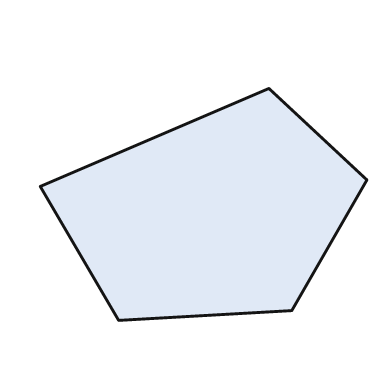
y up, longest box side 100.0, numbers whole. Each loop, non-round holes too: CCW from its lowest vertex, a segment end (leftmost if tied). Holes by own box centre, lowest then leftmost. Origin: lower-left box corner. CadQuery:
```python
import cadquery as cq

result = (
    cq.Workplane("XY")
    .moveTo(24.0, 0.0)
    .lineTo(77.0, 3.0)
    .lineTo(100.0, 43.0)
    .lineTo(70.0, 71.0)
    .lineTo(0.0, 41.0)
    .close()
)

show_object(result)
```